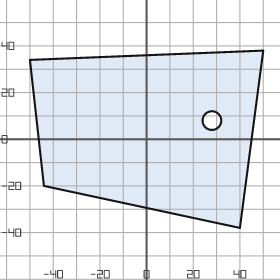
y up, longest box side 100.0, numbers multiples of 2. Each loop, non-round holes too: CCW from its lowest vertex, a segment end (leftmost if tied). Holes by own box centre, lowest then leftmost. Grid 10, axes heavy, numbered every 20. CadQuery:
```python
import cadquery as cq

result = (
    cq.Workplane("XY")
    .moveTo(40.0, -38.0)
    .lineTo(50.0, 38.0)
    .lineTo(-50.0, 34.0)
    .lineTo(-44.0, -20.0)
    .close()
    .moveTo(28.0, 8.0)
    .circle(4.0)
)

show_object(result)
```